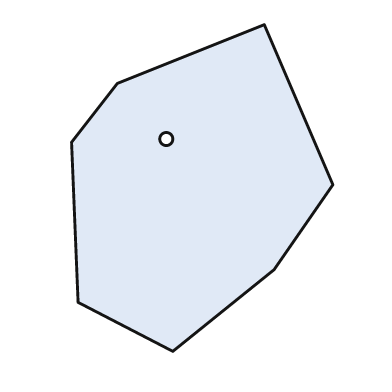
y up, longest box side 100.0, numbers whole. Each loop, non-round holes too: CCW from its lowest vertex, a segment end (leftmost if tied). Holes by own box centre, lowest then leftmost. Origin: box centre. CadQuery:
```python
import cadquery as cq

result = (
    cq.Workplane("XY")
    .moveTo(-9.0, -50.0)
    .lineTo(22.0, -25.0)
    .lineTo(40.0, 1.0)
    .lineTo(19.0, 50.0)
    .lineTo(-26.0, 32.0)
    .lineTo(-40.0, 14.0)
    .lineTo(-38.0, -35.0)
    .close()
    .moveTo(-11.0, 15.0)
    .circle(2.0)
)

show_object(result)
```